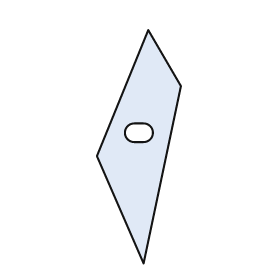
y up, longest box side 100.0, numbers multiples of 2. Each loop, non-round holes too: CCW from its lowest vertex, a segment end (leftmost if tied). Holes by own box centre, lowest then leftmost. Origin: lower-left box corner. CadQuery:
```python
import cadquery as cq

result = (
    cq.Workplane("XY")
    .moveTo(20.0, 0.0)
    .lineTo(36.0, 76.0)
    .lineTo(22.0, 100.0)
    .lineTo(0.0, 46.0)
    .close()
    .moveTo(16.0, 52.0)
    .lineTo(20.0, 52.0)
    .threePointArc((24.0, 56.0), (20.0, 60.0))
    .lineTo(16.0, 60.0)
    .threePointArc((12.0, 56.0), (16.0, 52.0))
    .close()
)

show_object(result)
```